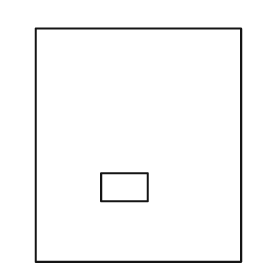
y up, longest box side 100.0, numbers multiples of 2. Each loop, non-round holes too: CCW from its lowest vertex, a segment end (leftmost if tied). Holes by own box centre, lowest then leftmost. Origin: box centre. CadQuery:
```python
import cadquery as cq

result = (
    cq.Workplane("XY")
    .moveTo(-44.0, -50.0)
    .lineTo(44.0, -50.0)
    .lineTo(44.0, 50.0)
    .lineTo(-44.0, 50.0)
    .close()
    .moveTo(-16.0, -24.0)
    .lineTo(4.0, -24.0)
    .lineTo(4.0, -12.0)
    .lineTo(-16.0, -12.0)
    .close()
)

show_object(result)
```